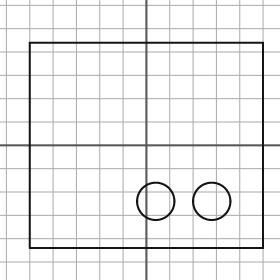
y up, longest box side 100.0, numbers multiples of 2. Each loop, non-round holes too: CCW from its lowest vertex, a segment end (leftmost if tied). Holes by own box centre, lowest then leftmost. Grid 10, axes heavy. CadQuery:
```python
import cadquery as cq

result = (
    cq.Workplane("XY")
    .moveTo(-50.0, -44.0)
    .lineTo(50.0, -44.0)
    .lineTo(50.0, 44.0)
    .lineTo(-50.0, 44.0)
    .close()
    .moveTo(4.0, -24.0)
    .circle(8.0)
    .moveTo(28.0, -24.0)
    .circle(8.0)
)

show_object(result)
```